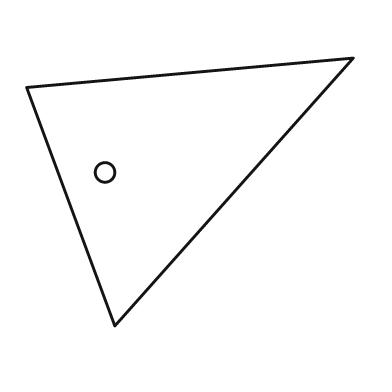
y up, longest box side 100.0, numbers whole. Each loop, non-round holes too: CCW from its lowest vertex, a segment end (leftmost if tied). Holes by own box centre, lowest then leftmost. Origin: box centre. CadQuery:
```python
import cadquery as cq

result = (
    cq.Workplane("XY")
    .moveTo(-23.0, -41.0)
    .lineTo(50.0, 41.0)
    .lineTo(-50.0, 32.0)
    .close()
    .moveTo(-26.0, 6.0)
    .circle(3.0)
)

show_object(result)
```